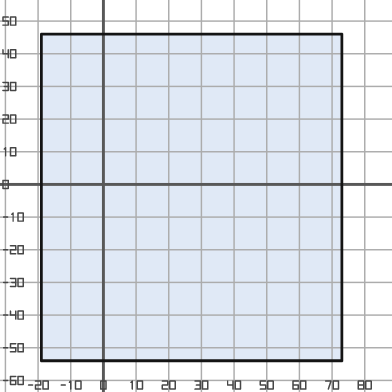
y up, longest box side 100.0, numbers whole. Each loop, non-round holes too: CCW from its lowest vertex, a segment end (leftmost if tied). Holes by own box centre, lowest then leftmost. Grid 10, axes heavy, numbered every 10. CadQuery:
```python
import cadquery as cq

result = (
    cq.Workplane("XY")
    .moveTo(-19.0, -54.0)
    .lineTo(73.0, -54.0)
    .lineTo(73.0, 46.0)
    .lineTo(-19.0, 46.0)
    .close()
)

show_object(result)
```